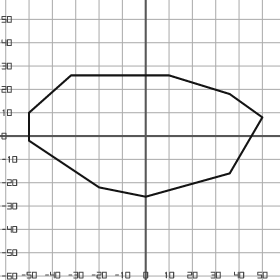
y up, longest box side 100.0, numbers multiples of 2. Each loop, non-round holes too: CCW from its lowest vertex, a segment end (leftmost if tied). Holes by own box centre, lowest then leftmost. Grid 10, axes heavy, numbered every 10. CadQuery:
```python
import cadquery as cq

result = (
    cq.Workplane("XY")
    .moveTo(0.0, -26.0)
    .lineTo(36.0, -16.0)
    .lineTo(50.0, 8.0)
    .lineTo(36.0, 18.0)
    .lineTo(10.0, 26.0)
    .lineTo(-32.0, 26.0)
    .lineTo(-50.0, 10.0)
    .lineTo(-50.0, -2.0)
    .lineTo(-20.0, -22.0)
    .close()
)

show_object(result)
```